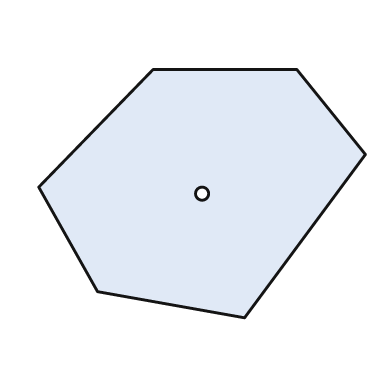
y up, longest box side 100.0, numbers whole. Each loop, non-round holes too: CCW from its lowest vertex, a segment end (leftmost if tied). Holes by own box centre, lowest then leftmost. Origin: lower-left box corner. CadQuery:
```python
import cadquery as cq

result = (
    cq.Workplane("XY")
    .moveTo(63.0, 0.0)
    .lineTo(100.0, 50.0)
    .lineTo(79.0, 76.0)
    .lineTo(35.0, 76.0)
    .lineTo(0.0, 40.0)
    .lineTo(18.0, 8.0)
    .close()
    .moveTo(50.0, 38.0)
    .circle(2.0)
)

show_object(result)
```